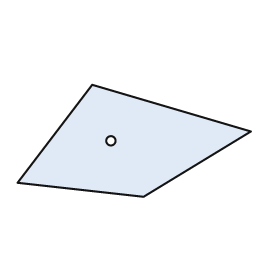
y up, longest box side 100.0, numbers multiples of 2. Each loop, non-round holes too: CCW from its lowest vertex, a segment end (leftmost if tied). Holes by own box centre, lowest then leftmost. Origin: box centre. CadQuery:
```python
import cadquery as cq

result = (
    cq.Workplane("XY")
    .moveTo(4.0, -24.0)
    .lineTo(50.0, 4.0)
    .lineTo(-18.0, 24.0)
    .lineTo(-50.0, -18.0)
    .close()
    .moveTo(-10.0, 0.0)
    .circle(2.0)
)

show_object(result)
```